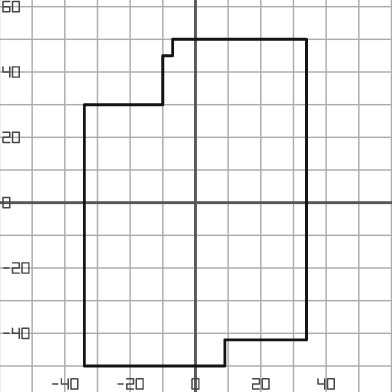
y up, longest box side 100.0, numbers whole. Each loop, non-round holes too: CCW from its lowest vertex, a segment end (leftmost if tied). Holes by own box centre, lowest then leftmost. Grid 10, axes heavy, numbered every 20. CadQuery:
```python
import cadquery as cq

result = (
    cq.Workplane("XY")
    .moveTo(-34.0, -50.0)
    .lineTo(9.0, -50.0)
    .lineTo(9.0, -42.0)
    .lineTo(34.0, -42.0)
    .lineTo(34.0, 50.0)
    .lineTo(-7.0, 50.0)
    .lineTo(-7.0, 45.0)
    .lineTo(-10.0, 45.0)
    .lineTo(-10.0, 30.0)
    .lineTo(-34.0, 30.0)
    .close()
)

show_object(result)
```